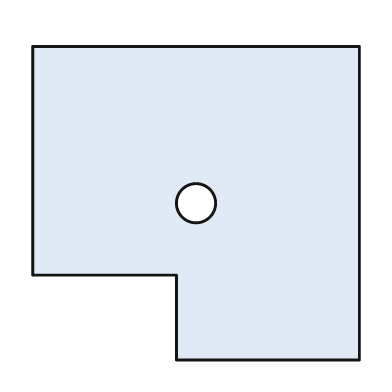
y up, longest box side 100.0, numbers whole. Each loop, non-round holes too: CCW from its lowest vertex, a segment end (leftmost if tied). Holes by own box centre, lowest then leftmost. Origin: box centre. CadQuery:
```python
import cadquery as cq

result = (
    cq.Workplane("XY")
    .moveTo(-6.0, -48.0)
    .lineTo(50.0, -48.0)
    .lineTo(50.0, 48.0)
    .lineTo(-50.0, 48.0)
    .lineTo(-50.0, -22.0)
    .lineTo(-6.0, -22.0)
    .close()
    .moveTo(0.0, 0.0)
    .circle(6.0)
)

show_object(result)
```